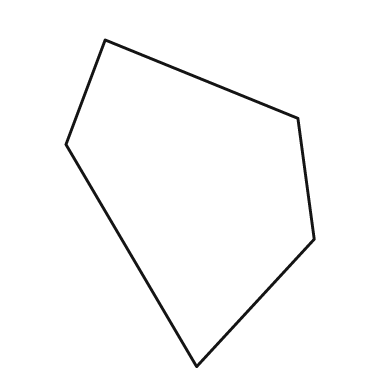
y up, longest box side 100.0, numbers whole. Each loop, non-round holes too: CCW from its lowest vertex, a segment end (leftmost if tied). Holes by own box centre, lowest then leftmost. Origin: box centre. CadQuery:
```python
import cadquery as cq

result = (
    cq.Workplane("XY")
    .moveTo(2.0, -50.0)
    .lineTo(38.0, -11.0)
    .lineTo(33.0, 26.0)
    .lineTo(-26.0, 50.0)
    .lineTo(-38.0, 18.0)
    .close()
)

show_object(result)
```